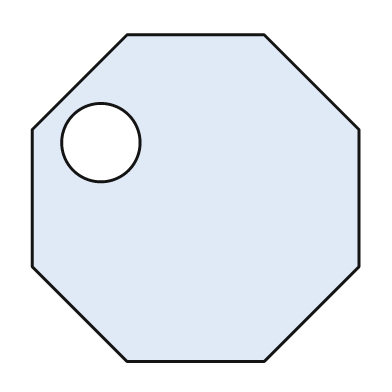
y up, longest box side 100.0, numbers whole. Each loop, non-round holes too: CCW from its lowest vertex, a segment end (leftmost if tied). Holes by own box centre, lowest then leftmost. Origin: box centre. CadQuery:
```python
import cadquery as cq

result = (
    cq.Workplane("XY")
    .moveTo(-21.0, -50.0)
    .lineTo(21.0, -50.0)
    .lineTo(50.0, -21.0)
    .lineTo(50.0, 21.0)
    .lineTo(21.0, 50.0)
    .lineTo(-21.0, 50.0)
    .lineTo(-50.0, 21.0)
    .lineTo(-50.0, -21.0)
    .close()
    .moveTo(-29.0, 17.0)
    .circle(12.0)
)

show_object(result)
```